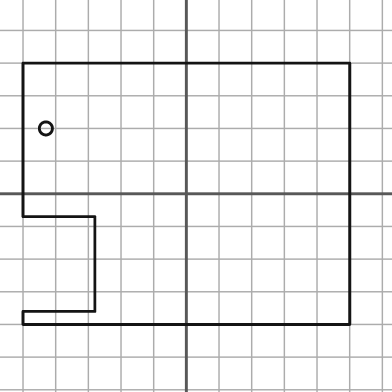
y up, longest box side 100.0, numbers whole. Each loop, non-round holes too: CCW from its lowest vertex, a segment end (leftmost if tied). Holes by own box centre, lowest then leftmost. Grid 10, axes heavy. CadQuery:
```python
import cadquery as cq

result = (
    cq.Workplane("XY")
    .moveTo(-50.0, -40.0)
    .lineTo(50.0, -40.0)
    .lineTo(50.0, 40.0)
    .lineTo(-50.0, 40.0)
    .lineTo(-50.0, -7.0)
    .lineTo(-28.0, -7.0)
    .lineTo(-28.0, -36.0)
    .lineTo(-50.0, -36.0)
    .close()
    .moveTo(-43.0, 20.0)
    .circle(2.0)
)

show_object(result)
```